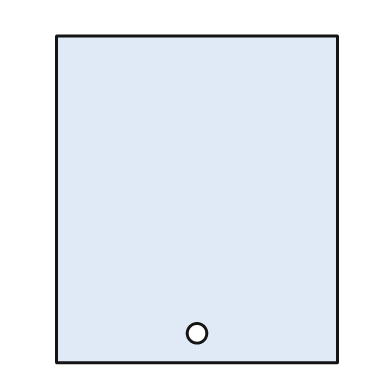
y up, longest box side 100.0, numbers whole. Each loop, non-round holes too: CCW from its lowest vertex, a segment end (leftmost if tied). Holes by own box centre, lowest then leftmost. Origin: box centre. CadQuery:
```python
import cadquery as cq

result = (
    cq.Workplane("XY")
    .moveTo(-43.0, -50.0)
    .lineTo(43.0, -50.0)
    .lineTo(43.0, 50.0)
    .lineTo(-43.0, 50.0)
    .close()
    .moveTo(0.0, -41.0)
    .circle(3.0)
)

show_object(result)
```